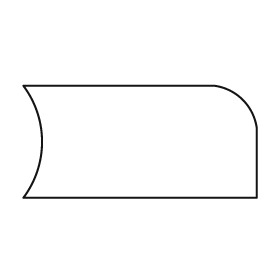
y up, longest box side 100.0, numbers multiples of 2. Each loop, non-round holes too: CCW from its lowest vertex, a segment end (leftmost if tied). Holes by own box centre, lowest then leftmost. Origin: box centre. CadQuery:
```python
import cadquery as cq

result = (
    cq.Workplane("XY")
    .moveTo(-50.0, -24.0)
    .lineTo(50.0, -24.0)
    .lineTo(50.0, 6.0)
    .threePointArc((44.0, 18.0), (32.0, 24.0))
    .lineTo(-50.0, 24.0)
    .threePointArc((-42.0, 0.0), (-50.0, -24.0))
    .close()
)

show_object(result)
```